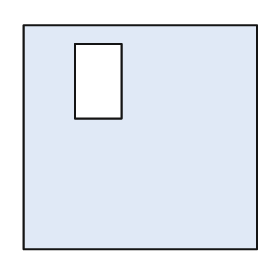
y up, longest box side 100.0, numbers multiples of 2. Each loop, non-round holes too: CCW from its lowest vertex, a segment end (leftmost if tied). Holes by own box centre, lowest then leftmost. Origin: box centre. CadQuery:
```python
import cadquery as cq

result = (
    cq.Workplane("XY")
    .moveTo(-50.0, -48.0)
    .lineTo(50.0, -48.0)
    .lineTo(50.0, 48.0)
    .lineTo(-50.0, 48.0)
    .close()
    .moveTo(-28.0, 8.0)
    .lineTo(-8.0, 8.0)
    .lineTo(-8.0, 40.0)
    .lineTo(-28.0, 40.0)
    .close()
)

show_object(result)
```